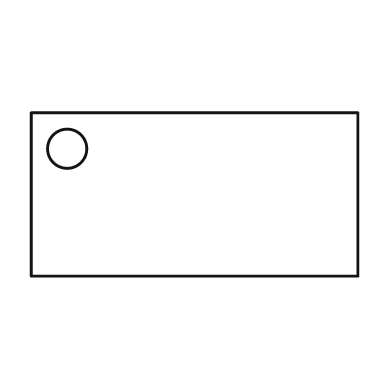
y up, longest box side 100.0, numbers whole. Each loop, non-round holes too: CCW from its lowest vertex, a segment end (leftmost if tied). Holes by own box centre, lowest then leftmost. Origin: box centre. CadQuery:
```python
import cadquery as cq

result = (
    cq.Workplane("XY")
    .moveTo(-50.0, -25.0)
    .lineTo(50.0, -25.0)
    .lineTo(50.0, 25.0)
    .lineTo(-50.0, 25.0)
    .close()
    .moveTo(-39.0, 14.0)
    .circle(6.0)
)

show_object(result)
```